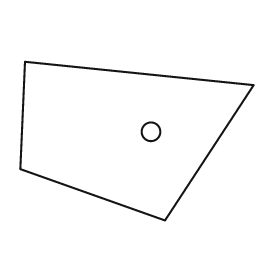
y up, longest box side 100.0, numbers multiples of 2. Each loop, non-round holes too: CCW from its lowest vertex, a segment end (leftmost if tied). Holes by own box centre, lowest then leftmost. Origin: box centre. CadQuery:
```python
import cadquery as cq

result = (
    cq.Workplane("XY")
    .moveTo(12.0, -34.0)
    .lineTo(50.0, 24.0)
    .lineTo(-48.0, 34.0)
    .lineTo(-50.0, -12.0)
    .close()
    .moveTo(6.0, 4.0)
    .circle(4.0)
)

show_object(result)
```